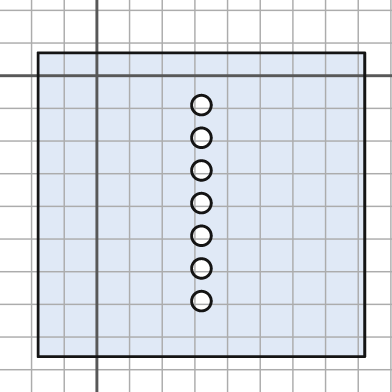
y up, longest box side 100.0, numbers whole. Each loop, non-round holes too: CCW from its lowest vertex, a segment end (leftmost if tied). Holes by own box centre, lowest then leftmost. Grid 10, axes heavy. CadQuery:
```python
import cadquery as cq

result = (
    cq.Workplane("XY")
    .moveTo(-18.0, -86.0)
    .lineTo(82.0, -86.0)
    .lineTo(82.0, 7.0)
    .lineTo(-18.0, 7.0)
    .close()
    .moveTo(32.0, -69.0)
    .circle(3.0)
    .moveTo(32.0, -59.0)
    .circle(3.0)
    .moveTo(32.0, -49.0)
    .circle(3.0)
    .moveTo(32.0, -39.0)
    .circle(3.0)
    .moveTo(32.0, -29.0)
    .circle(3.0)
    .moveTo(32.0, -19.0)
    .circle(3.0)
    .moveTo(32.0, -9.0)
    .circle(3.0)
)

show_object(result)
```